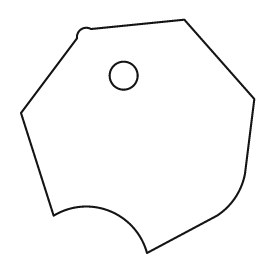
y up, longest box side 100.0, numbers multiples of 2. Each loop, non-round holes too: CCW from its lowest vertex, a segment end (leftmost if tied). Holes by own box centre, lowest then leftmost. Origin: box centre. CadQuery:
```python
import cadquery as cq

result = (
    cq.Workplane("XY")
    .moveTo(4.0, -50.0)
    .lineTo(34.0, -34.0)
    .threePointArc((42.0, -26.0), (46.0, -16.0))
    .lineTo(50.0, 16.0)
    .lineTo(20.0, 50.0)
    .lineTo(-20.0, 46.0)
    .threePointArc((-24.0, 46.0), (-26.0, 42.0))
    .lineTo(-50.0, 10.0)
    .lineTo(-36.0, -34.0)
    .threePointArc((-12.0, -32.0), (4.0, -50.0))
    .close()
    .moveTo(-6.0, 26.0)
    .circle(6.0)
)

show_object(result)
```